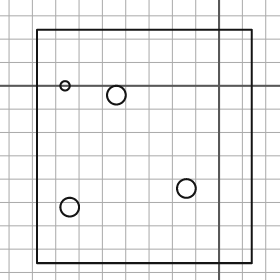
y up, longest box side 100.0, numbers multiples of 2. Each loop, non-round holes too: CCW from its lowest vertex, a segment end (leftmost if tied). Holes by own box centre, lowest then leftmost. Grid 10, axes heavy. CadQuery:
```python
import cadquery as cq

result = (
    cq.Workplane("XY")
    .moveTo(-78.0, -76.0)
    .lineTo(14.0, -76.0)
    .lineTo(14.0, 24.0)
    .lineTo(-78.0, 24.0)
    .close()
    .moveTo(-64.0, -52.0)
    .circle(4.0)
    .moveTo(-14.0, -44.0)
    .circle(4.0)
    .moveTo(-44.0, -4.0)
    .circle(4.0)
    .moveTo(-66.0, 0.0)
    .circle(2.0)
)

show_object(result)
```